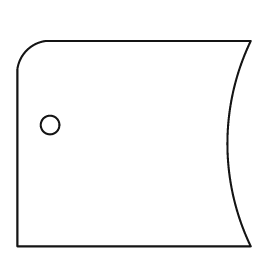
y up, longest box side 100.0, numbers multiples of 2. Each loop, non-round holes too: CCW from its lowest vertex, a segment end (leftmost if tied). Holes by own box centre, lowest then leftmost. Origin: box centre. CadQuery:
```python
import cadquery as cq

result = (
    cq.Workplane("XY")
    .moveTo(-50.0, -44.0)
    .lineTo(50.0, -44.0)
    .threePointArc((40.0, 0.0), (50.0, 44.0))
    .lineTo(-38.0, 44.0)
    .threePointArc((-46.0, 40.0), (-50.0, 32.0))
    .close()
    .moveTo(-36.0, 8.0)
    .circle(4.0)
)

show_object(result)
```